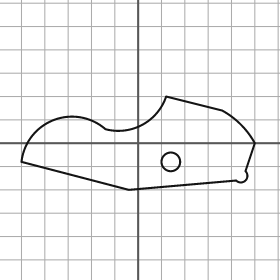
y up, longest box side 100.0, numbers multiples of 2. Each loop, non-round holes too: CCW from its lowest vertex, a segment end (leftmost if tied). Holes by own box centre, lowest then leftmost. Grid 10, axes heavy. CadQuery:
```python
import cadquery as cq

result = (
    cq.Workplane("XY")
    .moveTo(-4.0, -20.0)
    .lineTo(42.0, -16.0)
    .threePointArc((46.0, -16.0), (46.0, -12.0))
    .lineTo(50.0, 0.0)
    .threePointArc((44.0, 8.0), (36.0, 14.0))
    .lineTo(12.0, 20.0)
    .threePointArc((2.0, 8.0), (-14.0, 6.0))
    .threePointArc((-36.0, 10.0), (-50.0, -8.0))
    .close()
    .moveTo(14.0, -8.0)
    .circle(4.0)
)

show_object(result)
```